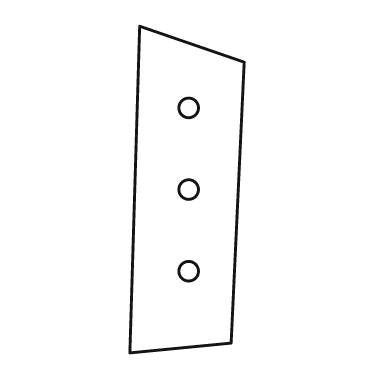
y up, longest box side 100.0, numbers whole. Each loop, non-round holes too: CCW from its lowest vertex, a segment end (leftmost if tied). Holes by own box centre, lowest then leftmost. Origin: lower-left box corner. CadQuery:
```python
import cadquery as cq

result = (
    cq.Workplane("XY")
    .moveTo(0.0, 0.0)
    .lineTo(31.0, 3.0)
    .lineTo(35.0, 89.0)
    .lineTo(3.0, 100.0)
    .close()
    .moveTo(18.0, 25.0)
    .circle(3.0)
    .moveTo(18.0, 50.0)
    .circle(3.0)
    .moveTo(18.0, 75.0)
    .circle(3.0)
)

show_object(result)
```